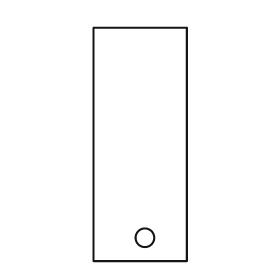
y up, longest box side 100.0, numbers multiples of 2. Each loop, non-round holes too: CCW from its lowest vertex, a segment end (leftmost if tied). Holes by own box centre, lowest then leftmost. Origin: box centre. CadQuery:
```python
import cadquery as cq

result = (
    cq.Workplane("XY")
    .moveTo(-20.0, -50.0)
    .lineTo(20.0, -50.0)
    .lineTo(20.0, 50.0)
    .lineTo(-20.0, 50.0)
    .close()
    .moveTo(2.0, -40.0)
    .circle(4.0)
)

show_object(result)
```